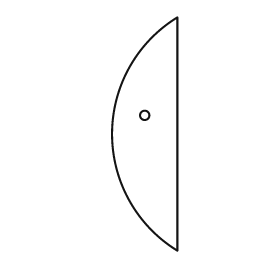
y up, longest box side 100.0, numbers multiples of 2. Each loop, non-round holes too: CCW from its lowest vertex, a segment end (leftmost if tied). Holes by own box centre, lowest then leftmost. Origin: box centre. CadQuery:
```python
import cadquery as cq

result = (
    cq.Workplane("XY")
    .moveTo(14.0, -50.0)
    .lineTo(14.0, 50.0)
    .threePointArc((-14.0, 0.0), (14.0, -50.0))
    .close()
    .moveTo(0.0, 8.0)
    .circle(2.0)
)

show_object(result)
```